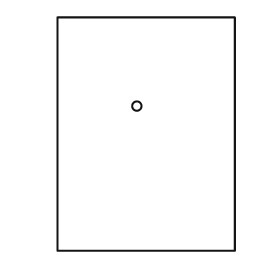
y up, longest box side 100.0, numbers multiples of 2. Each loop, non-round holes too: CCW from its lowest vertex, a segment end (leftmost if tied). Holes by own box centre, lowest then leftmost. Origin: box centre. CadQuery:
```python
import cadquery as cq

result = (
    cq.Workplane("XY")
    .moveTo(-38.0, -50.0)
    .lineTo(38.0, -50.0)
    .lineTo(38.0, 50.0)
    .lineTo(-38.0, 50.0)
    .close()
    .moveTo(-4.0, 12.0)
    .circle(2.0)
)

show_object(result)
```